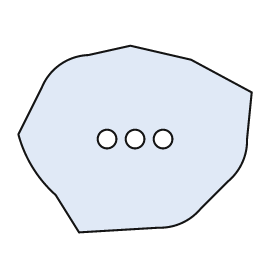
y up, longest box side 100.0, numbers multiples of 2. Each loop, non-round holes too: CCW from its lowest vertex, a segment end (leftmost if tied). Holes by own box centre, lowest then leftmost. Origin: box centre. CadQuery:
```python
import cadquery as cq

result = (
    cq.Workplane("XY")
    .moveTo(-24.0, -40.0)
    .lineTo(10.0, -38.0)
    .threePointArc((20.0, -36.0), (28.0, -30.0))
    .lineTo(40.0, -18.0)
    .threePointArc((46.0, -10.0), (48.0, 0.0))
    .lineTo(50.0, 20.0)
    .lineTo(24.0, 34.0)
    .lineTo(-2.0, 40.0)
    .lineTo(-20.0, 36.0)
    .threePointArc((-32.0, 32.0), (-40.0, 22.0))
    .lineTo(-50.0, 2.0)
    .threePointArc((-44.0, -12.0), (-34.0, -24.0))
    .close()
    .moveTo(-12.0, 0.0)
    .circle(4.0)
    .moveTo(0.0, 0.0)
    .circle(4.0)
    .moveTo(12.0, 0.0)
    .circle(4.0)
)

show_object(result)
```